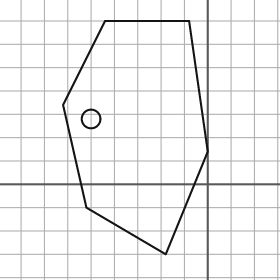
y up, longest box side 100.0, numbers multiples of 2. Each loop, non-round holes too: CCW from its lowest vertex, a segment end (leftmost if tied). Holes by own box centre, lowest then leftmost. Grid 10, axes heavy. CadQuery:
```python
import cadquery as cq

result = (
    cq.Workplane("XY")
    .moveTo(-18.0, -30.0)
    .lineTo(0.0, 14.0)
    .lineTo(-8.0, 70.0)
    .lineTo(-44.0, 70.0)
    .lineTo(-62.0, 34.0)
    .lineTo(-52.0, -10.0)
    .close()
    .moveTo(-50.0, 28.0)
    .circle(4.0)
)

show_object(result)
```